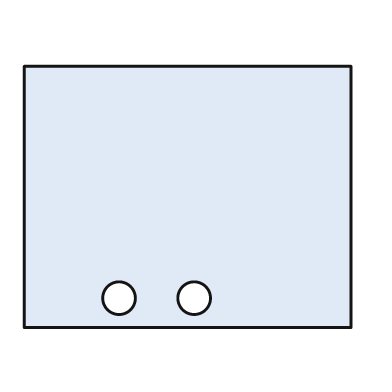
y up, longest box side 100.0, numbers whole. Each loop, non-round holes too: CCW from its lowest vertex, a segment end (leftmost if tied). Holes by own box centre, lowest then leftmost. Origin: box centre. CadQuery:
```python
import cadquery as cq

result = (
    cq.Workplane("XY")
    .moveTo(-50.0, -40.0)
    .lineTo(50.0, -40.0)
    .lineTo(50.0, 40.0)
    .lineTo(-50.0, 40.0)
    .close()
    .moveTo(-21.0, -31.0)
    .circle(5.0)
    .moveTo(2.0, -31.0)
    .circle(5.0)
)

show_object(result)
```